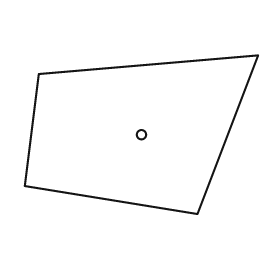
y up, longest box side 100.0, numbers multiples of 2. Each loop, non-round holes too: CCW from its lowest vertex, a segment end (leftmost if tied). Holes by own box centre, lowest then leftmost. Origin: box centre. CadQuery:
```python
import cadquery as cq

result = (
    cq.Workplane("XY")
    .moveTo(24.0, -34.0)
    .lineTo(50.0, 34.0)
    .lineTo(-44.0, 26.0)
    .lineTo(-50.0, -22.0)
    .close()
    .moveTo(0.0, 0.0)
    .circle(2.0)
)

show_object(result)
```